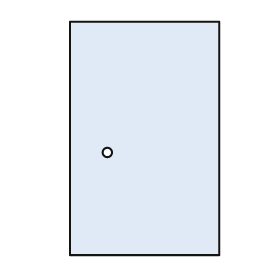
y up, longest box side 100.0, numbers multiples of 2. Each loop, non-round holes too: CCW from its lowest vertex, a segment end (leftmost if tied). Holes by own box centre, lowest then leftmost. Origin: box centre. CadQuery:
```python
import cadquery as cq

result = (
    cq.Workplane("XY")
    .moveTo(-32.0, -50.0)
    .lineTo(32.0, -50.0)
    .lineTo(32.0, 50.0)
    .lineTo(-32.0, 50.0)
    .close()
    .moveTo(-16.0, -6.0)
    .circle(2.0)
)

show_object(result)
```